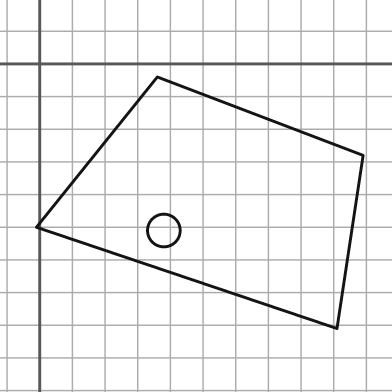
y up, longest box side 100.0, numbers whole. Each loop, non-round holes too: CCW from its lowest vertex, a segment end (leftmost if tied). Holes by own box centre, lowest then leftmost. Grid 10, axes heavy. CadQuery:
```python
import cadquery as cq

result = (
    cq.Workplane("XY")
    .moveTo(91.0, -81.0)
    .lineTo(99.0, -28.0)
    .lineTo(36.0, -4.0)
    .lineTo(-1.0, -50.0)
    .close()
    .moveTo(38.0, -51.0)
    .circle(5.0)
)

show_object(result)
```